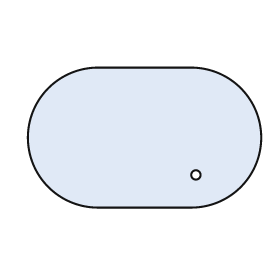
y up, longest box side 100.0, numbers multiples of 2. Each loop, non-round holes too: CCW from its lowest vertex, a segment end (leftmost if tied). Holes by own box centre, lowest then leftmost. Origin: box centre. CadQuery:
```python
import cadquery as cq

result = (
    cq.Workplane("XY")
    .moveTo(-20.0, -30.0)
    .lineTo(20.0, -30.0)
    .threePointArc((50.0, 0.0), (20.0, 30.0))
    .lineTo(-20.0, 30.0)
    .threePointArc((-50.0, 0.0), (-20.0, -30.0))
    .close()
    .moveTo(22.0, -16.0)
    .circle(2.0)
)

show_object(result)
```